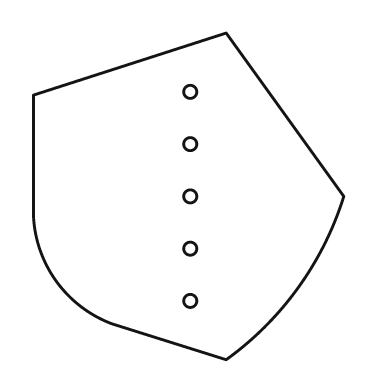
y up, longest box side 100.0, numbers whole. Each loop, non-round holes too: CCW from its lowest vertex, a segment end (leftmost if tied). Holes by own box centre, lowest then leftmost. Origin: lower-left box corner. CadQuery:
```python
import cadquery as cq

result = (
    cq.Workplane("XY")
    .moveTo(59.0, 0.0)
    .threePointArc((81.0, 22.0), (95.0, 50.0))
    .lineTo(59.0, 100.0)
    .lineTo(0.0, 81.0)
    .lineTo(0.0, 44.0)
    .threePointArc((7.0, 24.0), (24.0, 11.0))
    .close()
    .moveTo(48.0, 18.0)
    .circle(2.0)
    .moveTo(48.0, 34.0)
    .circle(2.0)
    .moveTo(48.0, 50.0)
    .circle(2.0)
    .moveTo(48.0, 66.0)
    .circle(2.0)
    .moveTo(48.0, 82.0)
    .circle(2.0)
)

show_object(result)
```